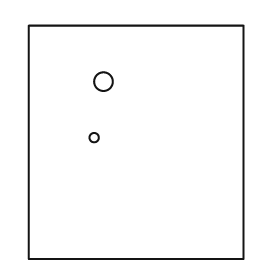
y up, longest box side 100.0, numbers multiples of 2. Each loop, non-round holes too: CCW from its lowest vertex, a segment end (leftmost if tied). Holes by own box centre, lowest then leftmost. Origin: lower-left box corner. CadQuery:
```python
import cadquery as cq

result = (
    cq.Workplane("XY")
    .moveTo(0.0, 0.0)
    .lineTo(92.0, 0.0)
    .lineTo(92.0, 100.0)
    .lineTo(0.0, 100.0)
    .close()
    .moveTo(28.0, 52.0)
    .circle(2.0)
    .moveTo(32.0, 76.0)
    .circle(4.0)
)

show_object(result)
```